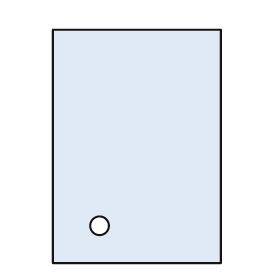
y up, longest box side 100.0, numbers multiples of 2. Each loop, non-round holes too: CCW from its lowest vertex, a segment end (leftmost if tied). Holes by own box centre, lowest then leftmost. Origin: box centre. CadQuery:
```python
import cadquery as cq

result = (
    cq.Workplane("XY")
    .moveTo(-36.0, -50.0)
    .lineTo(36.0, -50.0)
    .lineTo(36.0, 50.0)
    .lineTo(-36.0, 50.0)
    .close()
    .moveTo(-16.0, -34.0)
    .circle(4.0)
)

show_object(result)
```